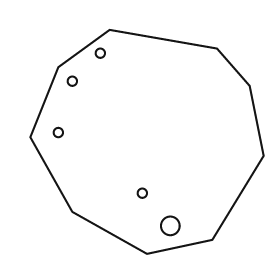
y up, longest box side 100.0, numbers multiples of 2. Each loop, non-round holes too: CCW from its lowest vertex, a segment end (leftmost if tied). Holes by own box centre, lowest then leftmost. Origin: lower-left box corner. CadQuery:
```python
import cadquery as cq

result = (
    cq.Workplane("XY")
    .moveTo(50.0, 0.0)
    .lineTo(78.0, 6.0)
    .lineTo(100.0, 42.0)
    .lineTo(94.0, 72.0)
    .lineTo(80.0, 88.0)
    .lineTo(34.0, 96.0)
    .lineTo(12.0, 80.0)
    .lineTo(0.0, 50.0)
    .lineTo(18.0, 18.0)
    .close()
    .moveTo(60.0, 12.0)
    .circle(4.0)
    .moveTo(48.0, 26.0)
    .circle(2.0)
    .moveTo(12.0, 52.0)
    .circle(2.0)
    .moveTo(18.0, 74.0)
    .circle(2.0)
    .moveTo(30.0, 86.0)
    .circle(2.0)
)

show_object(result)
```